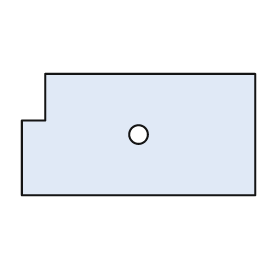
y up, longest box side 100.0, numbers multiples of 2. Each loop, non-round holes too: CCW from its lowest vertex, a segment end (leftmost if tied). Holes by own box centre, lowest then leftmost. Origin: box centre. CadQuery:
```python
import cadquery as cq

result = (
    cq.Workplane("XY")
    .moveTo(-50.0, -26.0)
    .lineTo(50.0, -26.0)
    .lineTo(50.0, 26.0)
    .lineTo(-40.0, 26.0)
    .lineTo(-40.0, 6.0)
    .lineTo(-50.0, 6.0)
    .close()
    .moveTo(0.0, 0.0)
    .circle(4.0)
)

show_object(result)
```